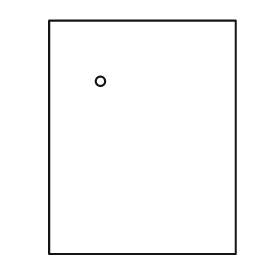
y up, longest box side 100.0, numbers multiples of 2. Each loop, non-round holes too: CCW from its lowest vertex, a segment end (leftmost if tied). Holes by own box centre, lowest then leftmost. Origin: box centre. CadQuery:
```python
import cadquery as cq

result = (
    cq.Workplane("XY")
    .moveTo(-40.0, -50.0)
    .lineTo(40.0, -50.0)
    .lineTo(40.0, 50.0)
    .lineTo(-40.0, 50.0)
    .close()
    .moveTo(-18.0, 24.0)
    .circle(2.0)
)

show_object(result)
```